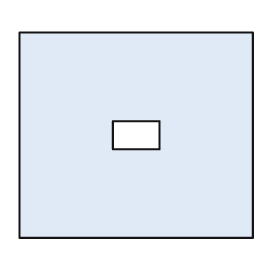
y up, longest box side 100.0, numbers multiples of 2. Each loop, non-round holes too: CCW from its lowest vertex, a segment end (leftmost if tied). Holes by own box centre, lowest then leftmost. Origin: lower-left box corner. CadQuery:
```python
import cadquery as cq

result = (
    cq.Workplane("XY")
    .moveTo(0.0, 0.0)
    .lineTo(100.0, 0.0)
    .lineTo(100.0, 88.0)
    .lineTo(0.0, 88.0)
    .close()
    .moveTo(40.0, 38.0)
    .lineTo(60.0, 38.0)
    .lineTo(60.0, 50.0)
    .lineTo(40.0, 50.0)
    .close()
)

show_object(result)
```